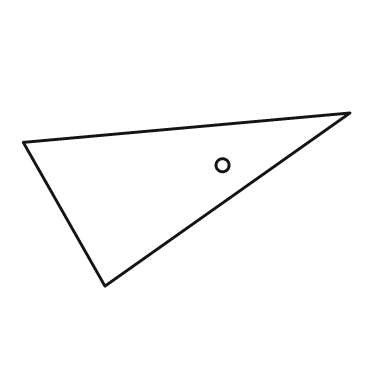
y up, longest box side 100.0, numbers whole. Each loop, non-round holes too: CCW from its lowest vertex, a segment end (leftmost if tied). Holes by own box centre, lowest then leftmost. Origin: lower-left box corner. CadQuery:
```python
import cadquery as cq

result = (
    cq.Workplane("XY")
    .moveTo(25.0, 0.0)
    .lineTo(100.0, 53.0)
    .lineTo(0.0, 44.0)
    .close()
    .moveTo(61.0, 37.0)
    .circle(2.0)
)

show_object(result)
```